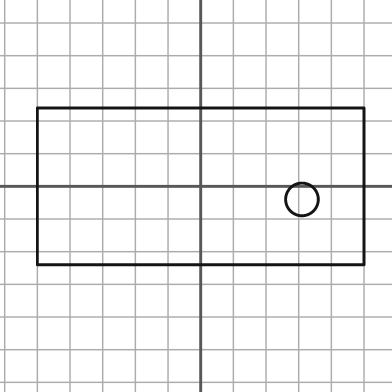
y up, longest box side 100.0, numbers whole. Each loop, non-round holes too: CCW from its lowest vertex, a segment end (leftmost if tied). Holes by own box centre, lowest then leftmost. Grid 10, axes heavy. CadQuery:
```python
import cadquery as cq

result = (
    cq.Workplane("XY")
    .moveTo(-50.0, -24.0)
    .lineTo(50.0, -24.0)
    .lineTo(50.0, 24.0)
    .lineTo(-50.0, 24.0)
    .close()
    .moveTo(31.0, -4.0)
    .circle(5.0)
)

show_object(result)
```